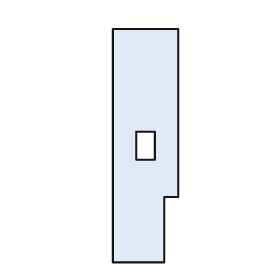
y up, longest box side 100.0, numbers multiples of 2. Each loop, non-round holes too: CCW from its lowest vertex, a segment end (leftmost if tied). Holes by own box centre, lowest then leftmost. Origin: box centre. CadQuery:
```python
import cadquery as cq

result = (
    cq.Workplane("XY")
    .moveTo(-14.0, -50.0)
    .lineTo(8.0, -50.0)
    .lineTo(8.0, -22.0)
    .lineTo(14.0, -22.0)
    .lineTo(14.0, 50.0)
    .lineTo(-14.0, 50.0)
    .close()
    .moveTo(-4.0, -6.0)
    .lineTo(4.0, -6.0)
    .lineTo(4.0, 6.0)
    .lineTo(-4.0, 6.0)
    .close()
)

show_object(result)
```